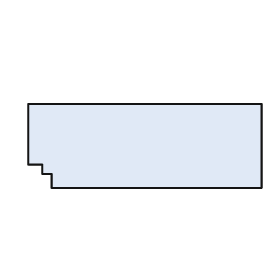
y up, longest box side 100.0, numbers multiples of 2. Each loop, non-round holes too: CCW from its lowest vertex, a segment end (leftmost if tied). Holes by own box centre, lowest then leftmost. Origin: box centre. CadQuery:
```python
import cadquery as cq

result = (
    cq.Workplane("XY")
    .moveTo(-40.0, -18.0)
    .lineTo(50.0, -18.0)
    .lineTo(50.0, 18.0)
    .lineTo(-50.0, 18.0)
    .lineTo(-50.0, -8.0)
    .lineTo(-44.0, -8.0)
    .lineTo(-44.0, -12.0)
    .lineTo(-40.0, -12.0)
    .close()
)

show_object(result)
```